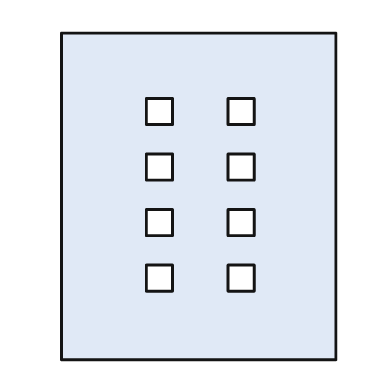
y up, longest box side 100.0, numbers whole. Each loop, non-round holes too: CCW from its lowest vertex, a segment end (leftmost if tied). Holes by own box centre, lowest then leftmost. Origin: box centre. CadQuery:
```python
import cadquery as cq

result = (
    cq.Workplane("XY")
    .moveTo(-42.0, -50.0)
    .lineTo(42.0, -50.0)
    .lineTo(42.0, 50.0)
    .lineTo(-42.0, 50.0)
    .close()
    .moveTo(-16.0, -29.0)
    .lineTo(-8.0, -29.0)
    .lineTo(-8.0, -21.0)
    .lineTo(-16.0, -21.0)
    .close()
    .moveTo(9.0, -29.0)
    .lineTo(17.0, -29.0)
    .lineTo(17.0, -21.0)
    .lineTo(9.0, -21.0)
    .close()
    .moveTo(-16.0, -12.0)
    .lineTo(-8.0, -12.0)
    .lineTo(-8.0, -4.0)
    .lineTo(-16.0, -4.0)
    .close()
    .moveTo(9.0, -12.0)
    .lineTo(17.0, -12.0)
    .lineTo(17.0, -4.0)
    .lineTo(9.0, -4.0)
    .close()
    .moveTo(-16.0, 5.0)
    .lineTo(-8.0, 5.0)
    .lineTo(-8.0, 13.0)
    .lineTo(-16.0, 13.0)
    .close()
    .moveTo(9.0, 5.0)
    .lineTo(17.0, 5.0)
    .lineTo(17.0, 13.0)
    .lineTo(9.0, 13.0)
    .close()
    .moveTo(-16.0, 22.0)
    .lineTo(-8.0, 22.0)
    .lineTo(-8.0, 30.0)
    .lineTo(-16.0, 30.0)
    .close()
    .moveTo(9.0, 22.0)
    .lineTo(17.0, 22.0)
    .lineTo(17.0, 30.0)
    .lineTo(9.0, 30.0)
    .close()
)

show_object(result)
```